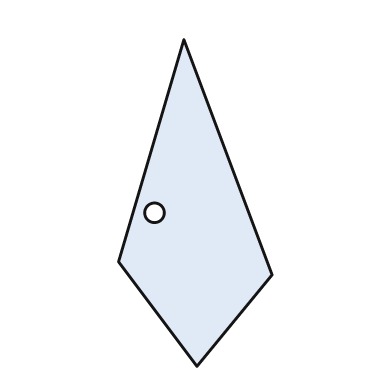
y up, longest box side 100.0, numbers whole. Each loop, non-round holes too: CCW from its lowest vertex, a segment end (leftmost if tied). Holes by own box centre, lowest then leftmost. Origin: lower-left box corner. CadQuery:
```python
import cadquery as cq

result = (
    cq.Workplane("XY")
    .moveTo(24.0, 0.0)
    .lineTo(47.0, 28.0)
    .lineTo(20.0, 100.0)
    .lineTo(0.0, 32.0)
    .close()
    .moveTo(11.0, 47.0)
    .circle(3.0)
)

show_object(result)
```